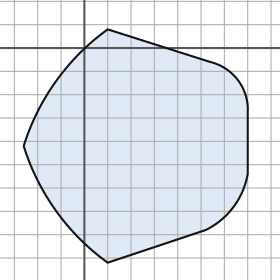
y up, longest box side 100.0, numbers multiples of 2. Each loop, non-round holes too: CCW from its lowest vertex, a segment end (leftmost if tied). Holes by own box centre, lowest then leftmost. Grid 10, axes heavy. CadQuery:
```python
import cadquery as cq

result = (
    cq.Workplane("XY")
    .moveTo(10.0, -92.0)
    .lineTo(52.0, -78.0)
    .threePointArc((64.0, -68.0), (70.0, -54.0))
    .lineTo(70.0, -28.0)
    .threePointArc((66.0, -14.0), (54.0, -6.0))
    .lineTo(10.0, 8.0)
    .threePointArc((-12.0, -14.0), (-26.0, -42.0))
    .threePointArc((-12.0, -70.0), (10.0, -92.0))
    .close()
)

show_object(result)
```